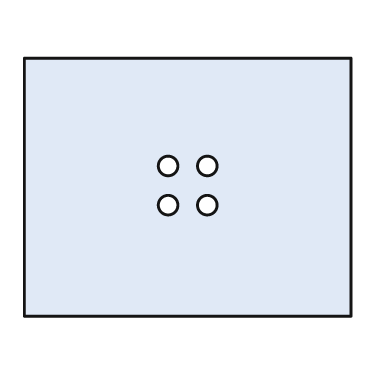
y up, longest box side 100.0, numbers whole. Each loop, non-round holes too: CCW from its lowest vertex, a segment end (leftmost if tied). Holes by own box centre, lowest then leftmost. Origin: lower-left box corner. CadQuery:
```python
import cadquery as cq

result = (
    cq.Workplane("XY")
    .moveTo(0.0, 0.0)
    .lineTo(100.0, 0.0)
    .lineTo(100.0, 79.0)
    .lineTo(0.0, 79.0)
    .close()
    .moveTo(44.0, 34.0)
    .circle(3.0)
    .moveTo(56.0, 34.0)
    .circle(3.0)
    .moveTo(44.0, 46.0)
    .circle(3.0)
    .moveTo(56.0, 46.0)
    .circle(3.0)
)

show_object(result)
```